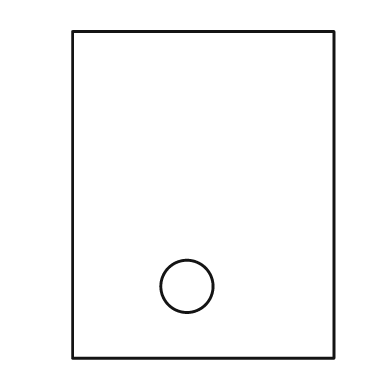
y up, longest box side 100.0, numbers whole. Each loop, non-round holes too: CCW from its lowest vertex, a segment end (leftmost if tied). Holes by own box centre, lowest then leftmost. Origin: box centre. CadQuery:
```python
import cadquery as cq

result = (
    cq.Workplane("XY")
    .moveTo(-40.0, -50.0)
    .lineTo(40.0, -50.0)
    .lineTo(40.0, 50.0)
    .lineTo(-40.0, 50.0)
    .close()
    .moveTo(-5.0, -28.0)
    .circle(8.0)
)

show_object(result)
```